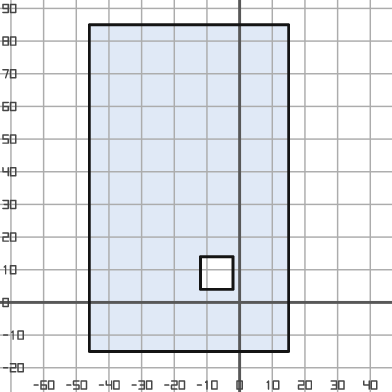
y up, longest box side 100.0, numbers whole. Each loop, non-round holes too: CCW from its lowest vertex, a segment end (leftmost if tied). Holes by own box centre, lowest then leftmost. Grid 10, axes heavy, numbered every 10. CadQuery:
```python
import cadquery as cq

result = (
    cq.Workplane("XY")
    .moveTo(-46.0, -15.0)
    .lineTo(15.0, -15.0)
    .lineTo(15.0, 85.0)
    .lineTo(-46.0, 85.0)
    .close()
    .moveTo(-12.0, 4.0)
    .lineTo(-2.0, 4.0)
    .lineTo(-2.0, 14.0)
    .lineTo(-12.0, 14.0)
    .close()
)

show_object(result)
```